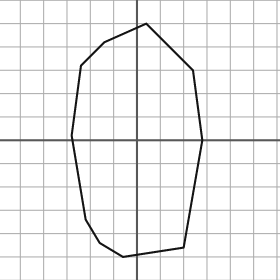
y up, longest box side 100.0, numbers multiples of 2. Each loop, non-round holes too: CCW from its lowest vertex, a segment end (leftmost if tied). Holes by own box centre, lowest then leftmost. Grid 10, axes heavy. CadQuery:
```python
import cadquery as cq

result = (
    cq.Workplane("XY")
    .moveTo(-6.0, -50.0)
    .lineTo(20.0, -46.0)
    .lineTo(28.0, 0.0)
    .lineTo(24.0, 30.0)
    .lineTo(4.0, 50.0)
    .lineTo(-14.0, 42.0)
    .lineTo(-24.0, 32.0)
    .lineTo(-28.0, 2.0)
    .lineTo(-22.0, -34.0)
    .lineTo(-16.0, -44.0)
    .close()
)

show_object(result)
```